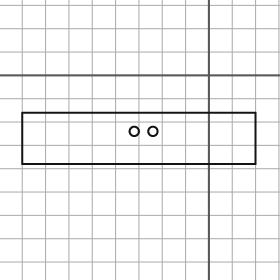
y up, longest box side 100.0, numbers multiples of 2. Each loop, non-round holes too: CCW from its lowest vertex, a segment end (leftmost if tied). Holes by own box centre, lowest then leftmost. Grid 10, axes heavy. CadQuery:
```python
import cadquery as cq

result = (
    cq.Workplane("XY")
    .moveTo(-80.0, -38.0)
    .lineTo(20.0, -38.0)
    .lineTo(20.0, -16.0)
    .lineTo(-80.0, -16.0)
    .close()
    .moveTo(-32.0, -24.0)
    .circle(2.0)
    .moveTo(-24.0, -24.0)
    .circle(2.0)
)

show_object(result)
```